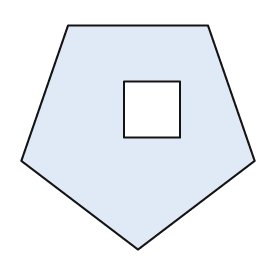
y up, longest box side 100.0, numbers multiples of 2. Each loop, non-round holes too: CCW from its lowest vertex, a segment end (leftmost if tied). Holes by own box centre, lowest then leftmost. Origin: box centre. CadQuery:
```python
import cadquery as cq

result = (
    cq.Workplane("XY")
    .moveTo(0.0, -48.0)
    .lineTo(50.0, -10.0)
    .lineTo(30.0, 48.0)
    .lineTo(-30.0, 48.0)
    .lineTo(-50.0, -10.0)
    .close()
    .moveTo(-6.0, 0.0)
    .lineTo(18.0, 0.0)
    .lineTo(18.0, 24.0)
    .lineTo(-6.0, 24.0)
    .close()
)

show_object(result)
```